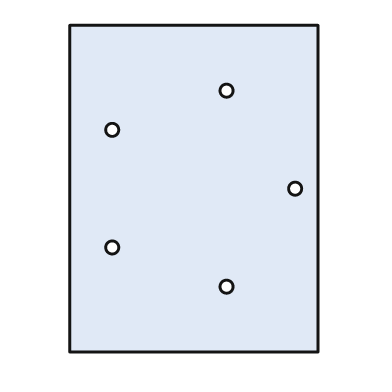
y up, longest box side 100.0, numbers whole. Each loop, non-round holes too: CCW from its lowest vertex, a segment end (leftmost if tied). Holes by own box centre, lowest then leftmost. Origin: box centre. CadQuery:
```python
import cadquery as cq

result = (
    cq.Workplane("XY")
    .moveTo(-38.0, -50.0)
    .lineTo(38.0, -50.0)
    .lineTo(38.0, 50.0)
    .lineTo(-38.0, 50.0)
    .close()
    .moveTo(10.0, -30.0)
    .circle(2.0)
    .moveTo(-25.0, -18.0)
    .circle(2.0)
    .moveTo(31.0, 0.0)
    .circle(2.0)
    .moveTo(-25.0, 18.0)
    .circle(2.0)
    .moveTo(10.0, 30.0)
    .circle(2.0)
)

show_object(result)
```